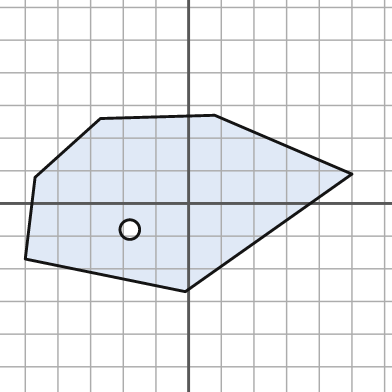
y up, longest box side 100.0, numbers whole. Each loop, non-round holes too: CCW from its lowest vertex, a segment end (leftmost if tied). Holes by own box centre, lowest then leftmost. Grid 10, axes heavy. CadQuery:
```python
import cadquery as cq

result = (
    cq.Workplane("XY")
    .moveTo(-1.0, -27.0)
    .lineTo(50.0, 9.0)
    .lineTo(8.0, 27.0)
    .lineTo(-27.0, 26.0)
    .lineTo(-47.0, 8.0)
    .lineTo(-50.0, -17.0)
    .close()
    .moveTo(-18.0, -8.0)
    .circle(3.0)
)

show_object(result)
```